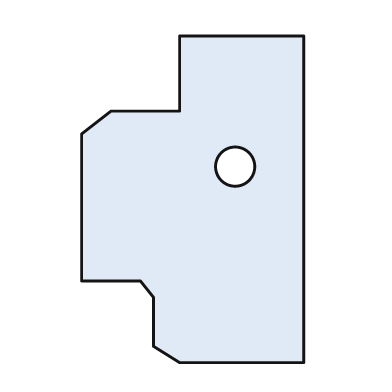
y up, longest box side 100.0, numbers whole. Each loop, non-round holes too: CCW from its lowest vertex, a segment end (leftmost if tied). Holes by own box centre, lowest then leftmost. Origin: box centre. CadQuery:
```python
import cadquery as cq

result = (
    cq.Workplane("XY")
    .moveTo(-4.0, -50.0)
    .lineTo(34.0, -50.0)
    .lineTo(34.0, 50.0)
    .lineTo(-4.0, 50.0)
    .lineTo(-4.0, 27.0)
    .lineTo(-25.0, 27.0)
    .lineTo(-34.0, 20.0)
    .lineTo(-34.0, -25.0)
    .lineTo(-16.0, -25.0)
    .lineTo(-12.0, -30.0)
    .lineTo(-12.0, -45.0)
    .close()
    .moveTo(13.0, 10.0)
    .circle(6.0)
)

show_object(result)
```